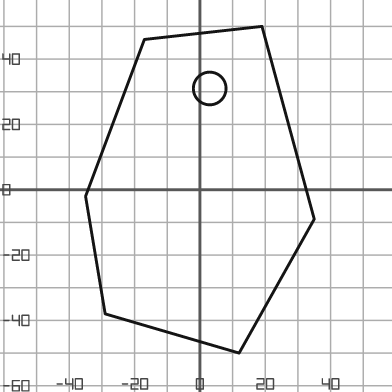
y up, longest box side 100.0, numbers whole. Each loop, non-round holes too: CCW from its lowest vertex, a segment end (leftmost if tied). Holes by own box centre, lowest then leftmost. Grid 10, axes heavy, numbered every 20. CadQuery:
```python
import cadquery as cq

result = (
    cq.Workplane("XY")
    .moveTo(12.0, -50.0)
    .lineTo(35.0, -9.0)
    .lineTo(19.0, 50.0)
    .lineTo(-17.0, 46.0)
    .lineTo(-35.0, -2.0)
    .lineTo(-29.0, -38.0)
    .close()
    .moveTo(3.0, 31.0)
    .circle(5.0)
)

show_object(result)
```